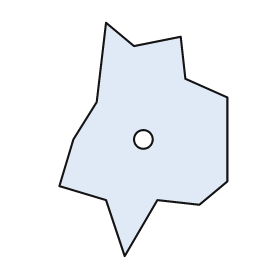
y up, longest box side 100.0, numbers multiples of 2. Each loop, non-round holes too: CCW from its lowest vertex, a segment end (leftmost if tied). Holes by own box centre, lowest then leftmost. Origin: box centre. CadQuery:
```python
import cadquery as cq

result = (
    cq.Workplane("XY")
    .moveTo(-8.0, -50.0)
    .lineTo(6.0, -26.0)
    .lineTo(24.0, -28.0)
    .lineTo(36.0, -18.0)
    .lineTo(36.0, 18.0)
    .lineTo(18.0, 26.0)
    .lineTo(16.0, 44.0)
    .lineTo(-4.0, 40.0)
    .lineTo(-16.0, 50.0)
    .lineTo(-20.0, 16.0)
    .lineTo(-30.0, 0.0)
    .lineTo(-36.0, -20.0)
    .lineTo(-16.0, -26.0)
    .close()
    .moveTo(0.0, 0.0)
    .circle(4.0)
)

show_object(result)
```